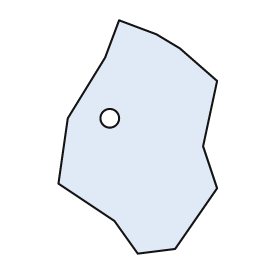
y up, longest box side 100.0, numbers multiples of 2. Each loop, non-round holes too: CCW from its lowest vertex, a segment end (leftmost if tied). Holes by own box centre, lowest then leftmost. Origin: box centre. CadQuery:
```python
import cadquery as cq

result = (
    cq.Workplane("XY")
    .moveTo(0.0, -50.0)
    .lineTo(16.0, -48.0)
    .lineTo(34.0, -22.0)
    .lineTo(28.0, -4.0)
    .lineTo(34.0, 24.0)
    .lineTo(18.0, 38.0)
    .lineTo(8.0, 44.0)
    .lineTo(-8.0, 50.0)
    .lineTo(-14.0, 34.0)
    .lineTo(-30.0, 8.0)
    .lineTo(-34.0, -20.0)
    .lineTo(-10.0, -36.0)
    .close()
    .moveTo(-12.0, 8.0)
    .circle(4.0)
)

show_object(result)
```